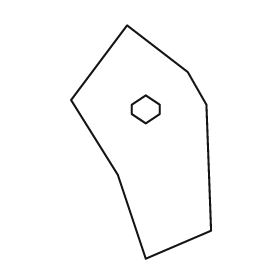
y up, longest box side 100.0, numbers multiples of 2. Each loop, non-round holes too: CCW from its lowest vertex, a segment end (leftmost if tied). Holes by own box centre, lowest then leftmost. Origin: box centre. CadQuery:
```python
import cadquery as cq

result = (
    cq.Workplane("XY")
    .moveTo(2.0, -50.0)
    .lineTo(30.0, -38.0)
    .lineTo(28.0, 16.0)
    .lineTo(20.0, 30.0)
    .lineTo(-6.0, 50.0)
    .lineTo(-30.0, 18.0)
    .lineTo(-10.0, -14.0)
    .close()
    .moveTo(2.0, 8.0)
    .lineTo(8.0, 12.0)
    .lineTo(8.0, 16.0)
    .lineTo(2.0, 20.0)
    .lineTo(-4.0, 16.0)
    .lineTo(-4.0, 12.0)
    .close()
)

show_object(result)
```